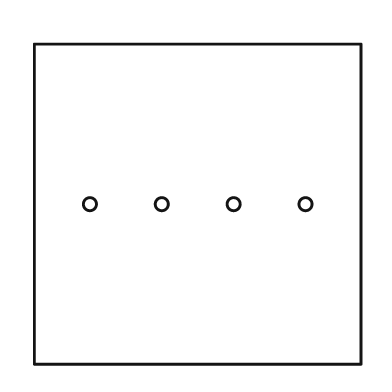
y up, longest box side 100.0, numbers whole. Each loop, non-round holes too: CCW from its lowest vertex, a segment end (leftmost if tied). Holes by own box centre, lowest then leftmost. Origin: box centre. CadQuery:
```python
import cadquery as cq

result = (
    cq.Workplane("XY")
    .moveTo(-50.0, -49.0)
    .lineTo(50.0, -49.0)
    .lineTo(50.0, 49.0)
    .lineTo(-50.0, 49.0)
    .close()
    .moveTo(-33.0, 0.0)
    .circle(2.0)
    .moveTo(-11.0, 0.0)
    .circle(2.0)
    .moveTo(11.0, 0.0)
    .circle(2.0)
    .moveTo(33.0, 0.0)
    .circle(2.0)
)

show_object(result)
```